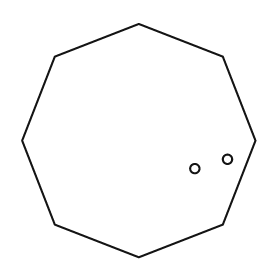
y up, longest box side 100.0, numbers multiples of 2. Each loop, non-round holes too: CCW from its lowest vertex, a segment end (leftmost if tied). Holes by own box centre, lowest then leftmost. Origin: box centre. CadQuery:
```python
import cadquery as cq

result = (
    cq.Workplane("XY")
    .moveTo(0.0, -50.0)
    .lineTo(36.0, -36.0)
    .lineTo(50.0, 0.0)
    .lineTo(36.0, 36.0)
    .lineTo(0.0, 50.0)
    .lineTo(-36.0, 36.0)
    .lineTo(-50.0, 0.0)
    .lineTo(-36.0, -36.0)
    .close()
    .moveTo(24.0, -12.0)
    .circle(2.0)
    .moveTo(38.0, -8.0)
    .circle(2.0)
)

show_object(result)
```